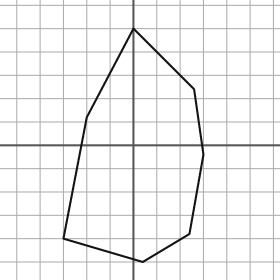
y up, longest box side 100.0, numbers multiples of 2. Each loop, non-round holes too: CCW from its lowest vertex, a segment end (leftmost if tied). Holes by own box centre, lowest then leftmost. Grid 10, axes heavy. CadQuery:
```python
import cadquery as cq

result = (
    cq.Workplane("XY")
    .moveTo(4.0, -50.0)
    .lineTo(24.0, -38.0)
    .lineTo(30.0, -4.0)
    .lineTo(26.0, 24.0)
    .lineTo(0.0, 50.0)
    .lineTo(-20.0, 12.0)
    .lineTo(-30.0, -40.0)
    .close()
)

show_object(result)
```